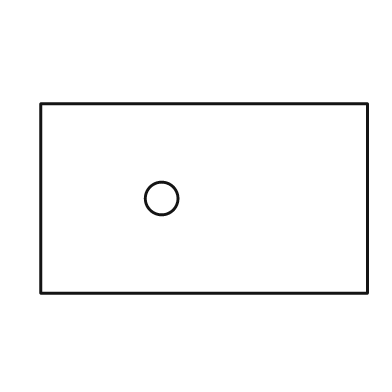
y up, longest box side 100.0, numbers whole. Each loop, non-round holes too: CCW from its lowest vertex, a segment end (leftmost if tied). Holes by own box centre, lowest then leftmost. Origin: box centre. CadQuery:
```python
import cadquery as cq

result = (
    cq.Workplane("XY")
    .moveTo(-50.0, -29.0)
    .lineTo(50.0, -29.0)
    .lineTo(50.0, 29.0)
    .lineTo(-50.0, 29.0)
    .close()
    .moveTo(-13.0, 0.0)
    .circle(5.0)
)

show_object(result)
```